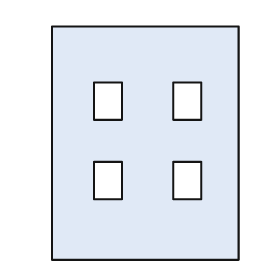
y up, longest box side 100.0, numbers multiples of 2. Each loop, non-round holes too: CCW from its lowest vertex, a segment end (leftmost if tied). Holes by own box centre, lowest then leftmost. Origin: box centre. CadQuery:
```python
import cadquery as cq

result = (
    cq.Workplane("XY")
    .moveTo(-40.0, -50.0)
    .lineTo(40.0, -50.0)
    .lineTo(40.0, 50.0)
    .lineTo(-40.0, 50.0)
    .close()
    .moveTo(-22.0, -24.0)
    .lineTo(-10.0, -24.0)
    .lineTo(-10.0, -8.0)
    .lineTo(-22.0, -8.0)
    .close()
    .moveTo(12.0, -24.0)
    .lineTo(24.0, -24.0)
    .lineTo(24.0, -8.0)
    .lineTo(12.0, -8.0)
    .close()
    .moveTo(-22.0, 10.0)
    .lineTo(-10.0, 10.0)
    .lineTo(-10.0, 26.0)
    .lineTo(-22.0, 26.0)
    .close()
    .moveTo(12.0, 10.0)
    .lineTo(24.0, 10.0)
    .lineTo(24.0, 26.0)
    .lineTo(12.0, 26.0)
    .close()
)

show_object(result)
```